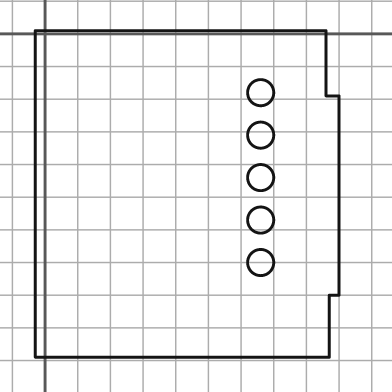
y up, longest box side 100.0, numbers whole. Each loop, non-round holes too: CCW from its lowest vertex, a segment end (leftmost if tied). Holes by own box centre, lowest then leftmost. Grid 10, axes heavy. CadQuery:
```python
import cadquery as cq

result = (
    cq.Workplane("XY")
    .moveTo(-3.0, -99.0)
    .lineTo(87.0, -99.0)
    .lineTo(87.0, -80.0)
    .lineTo(90.0, -80.0)
    .lineTo(90.0, -19.0)
    .lineTo(86.0, -19.0)
    .lineTo(86.0, 1.0)
    .lineTo(-3.0, 1.0)
    .close()
    .moveTo(66.0, -70.0)
    .circle(4.0)
    .moveTo(66.0, -57.0)
    .circle(4.0)
    .moveTo(66.0, -44.0)
    .circle(4.0)
    .moveTo(66.0, -31.0)
    .circle(4.0)
    .moveTo(66.0, -18.0)
    .circle(4.0)
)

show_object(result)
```